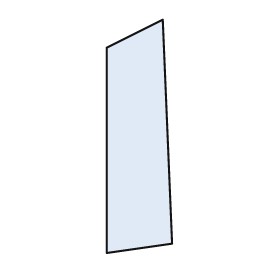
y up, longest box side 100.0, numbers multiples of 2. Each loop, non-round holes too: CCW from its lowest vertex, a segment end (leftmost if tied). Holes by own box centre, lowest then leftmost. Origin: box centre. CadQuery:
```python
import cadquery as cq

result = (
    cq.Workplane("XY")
    .moveTo(-14.0, -50.0)
    .lineTo(14.0, -46.0)
    .lineTo(10.0, 50.0)
    .lineTo(-14.0, 38.0)
    .close()
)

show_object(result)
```